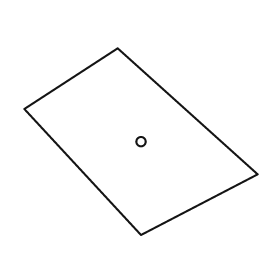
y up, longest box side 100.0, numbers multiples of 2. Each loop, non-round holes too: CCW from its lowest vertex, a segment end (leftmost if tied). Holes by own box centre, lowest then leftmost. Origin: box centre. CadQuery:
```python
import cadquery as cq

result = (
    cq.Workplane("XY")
    .moveTo(0.0, -40.0)
    .lineTo(50.0, -14.0)
    .lineTo(-10.0, 40.0)
    .lineTo(-50.0, 14.0)
    .close()
    .moveTo(0.0, 0.0)
    .circle(2.0)
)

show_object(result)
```